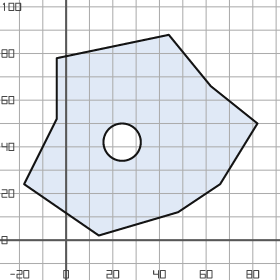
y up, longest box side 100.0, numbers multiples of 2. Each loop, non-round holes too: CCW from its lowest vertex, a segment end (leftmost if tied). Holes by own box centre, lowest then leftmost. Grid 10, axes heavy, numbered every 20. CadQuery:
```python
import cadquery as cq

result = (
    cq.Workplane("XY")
    .moveTo(14.0, 2.0)
    .lineTo(48.0, 12.0)
    .lineTo(66.0, 24.0)
    .lineTo(82.0, 50.0)
    .lineTo(62.0, 66.0)
    .lineTo(44.0, 88.0)
    .lineTo(-4.0, 78.0)
    .lineTo(-4.0, 52.0)
    .lineTo(-18.0, 24.0)
    .close()
    .moveTo(24.0, 42.0)
    .circle(8.0)
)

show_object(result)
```